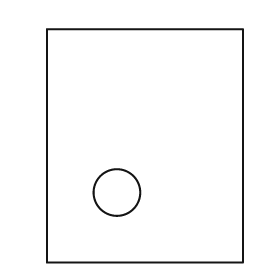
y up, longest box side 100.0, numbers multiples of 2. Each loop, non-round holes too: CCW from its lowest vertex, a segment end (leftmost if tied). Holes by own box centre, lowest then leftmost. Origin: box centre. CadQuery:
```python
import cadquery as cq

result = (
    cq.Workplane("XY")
    .moveTo(-42.0, -50.0)
    .lineTo(42.0, -50.0)
    .lineTo(42.0, 50.0)
    .lineTo(-42.0, 50.0)
    .close()
    .moveTo(-12.0, -20.0)
    .circle(10.0)
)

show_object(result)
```